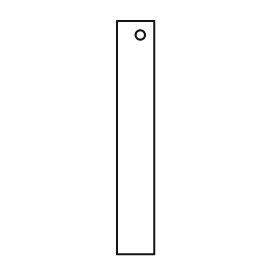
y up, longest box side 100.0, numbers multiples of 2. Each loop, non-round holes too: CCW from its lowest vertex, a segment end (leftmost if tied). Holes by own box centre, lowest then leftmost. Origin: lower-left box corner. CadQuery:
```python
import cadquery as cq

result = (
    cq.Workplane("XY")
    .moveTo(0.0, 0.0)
    .lineTo(16.0, 0.0)
    .lineTo(16.0, 100.0)
    .lineTo(0.0, 100.0)
    .close()
    .moveTo(10.0, 94.0)
    .circle(2.0)
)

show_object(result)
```